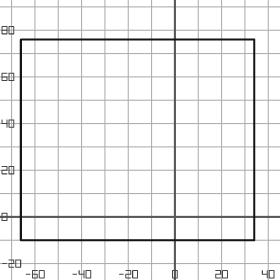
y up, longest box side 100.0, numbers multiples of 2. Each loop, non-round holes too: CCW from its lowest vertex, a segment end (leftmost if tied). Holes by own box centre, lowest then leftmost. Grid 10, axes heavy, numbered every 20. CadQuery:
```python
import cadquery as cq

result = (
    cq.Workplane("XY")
    .moveTo(-66.0, -10.0)
    .lineTo(34.0, -10.0)
    .lineTo(34.0, 76.0)
    .lineTo(-66.0, 76.0)
    .close()
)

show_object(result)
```